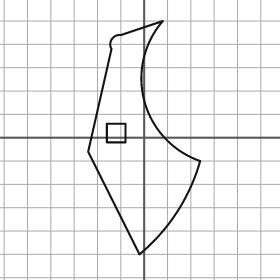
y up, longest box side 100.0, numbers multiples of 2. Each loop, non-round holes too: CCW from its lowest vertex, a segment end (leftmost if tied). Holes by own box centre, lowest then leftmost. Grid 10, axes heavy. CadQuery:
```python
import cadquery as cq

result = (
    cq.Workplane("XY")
    .moveTo(-2.0, -50.0)
    .threePointArc((14.0, -32.0), (24.0, -10.0))
    .threePointArc((0.0, 16.0), (8.0, 50.0))
    .lineTo(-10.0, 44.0)
    .threePointArc((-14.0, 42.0), (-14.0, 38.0))
    .lineTo(-24.0, -6.0)
    .close()
    .moveTo(-16.0, -2.0)
    .lineTo(-8.0, -2.0)
    .lineTo(-8.0, 6.0)
    .lineTo(-16.0, 6.0)
    .close()
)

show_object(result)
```